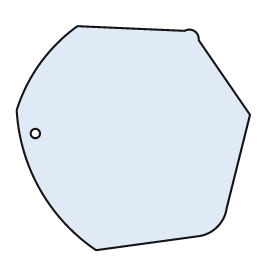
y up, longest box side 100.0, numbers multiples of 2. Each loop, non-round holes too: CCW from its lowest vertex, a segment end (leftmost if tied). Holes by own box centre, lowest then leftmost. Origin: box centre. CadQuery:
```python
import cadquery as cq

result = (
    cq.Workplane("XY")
    .moveTo(-16.0, -48.0)
    .lineTo(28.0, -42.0)
    .threePointArc((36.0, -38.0), (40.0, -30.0))
    .lineTo(50.0, 10.0)
    .lineTo(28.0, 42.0)
    .threePointArc((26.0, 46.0), (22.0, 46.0))
    .lineTo(-24.0, 48.0)
    .threePointArc((-40.0, 32.0), (-50.0, 12.0))
    .threePointArc((-40.0, -22.0), (-16.0, -48.0))
    .close()
    .moveTo(-42.0, 2.0)
    .circle(2.0)
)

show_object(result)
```